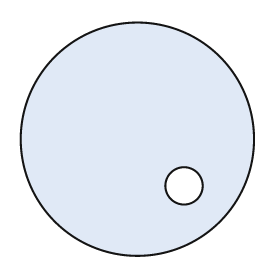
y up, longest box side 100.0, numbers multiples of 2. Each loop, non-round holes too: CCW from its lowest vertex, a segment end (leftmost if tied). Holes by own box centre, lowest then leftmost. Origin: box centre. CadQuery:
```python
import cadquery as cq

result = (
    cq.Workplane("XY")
    .moveTo(0.0, 0.0)
    .circle(50.0)
    .moveTo(20.0, -20.0)
    .circle(8.0)
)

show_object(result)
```